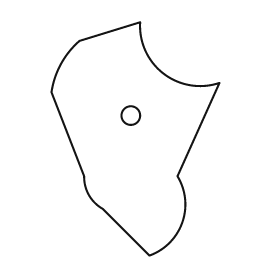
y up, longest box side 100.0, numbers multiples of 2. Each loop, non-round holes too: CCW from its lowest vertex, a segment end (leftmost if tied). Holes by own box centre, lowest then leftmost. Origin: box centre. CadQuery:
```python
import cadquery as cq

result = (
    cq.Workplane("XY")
    .moveTo(6.0, -50.0)
    .threePointArc((20.0, -36.0), (18.0, -16.0))
    .lineTo(36.0, 24.0)
    .threePointArc((12.0, 28.0), (2.0, 50.0))
    .lineTo(-24.0, 42.0)
    .threePointArc((-32.0, 32.0), (-36.0, 20.0))
    .lineTo(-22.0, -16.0)
    .threePointArc((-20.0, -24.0), (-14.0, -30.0))
    .close()
    .moveTo(-2.0, 10.0)
    .circle(4.0)
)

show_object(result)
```